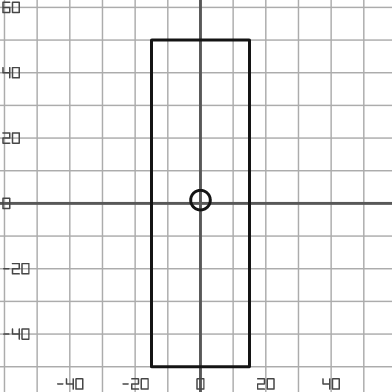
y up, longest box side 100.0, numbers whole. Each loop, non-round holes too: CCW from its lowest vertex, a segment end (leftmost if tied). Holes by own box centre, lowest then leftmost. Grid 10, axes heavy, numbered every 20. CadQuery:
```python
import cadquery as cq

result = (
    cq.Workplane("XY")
    .moveTo(-15.0, -50.0)
    .lineTo(15.0, -50.0)
    .lineTo(15.0, 50.0)
    .lineTo(-15.0, 50.0)
    .close()
    .moveTo(0.0, 1.0)
    .circle(3.0)
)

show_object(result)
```